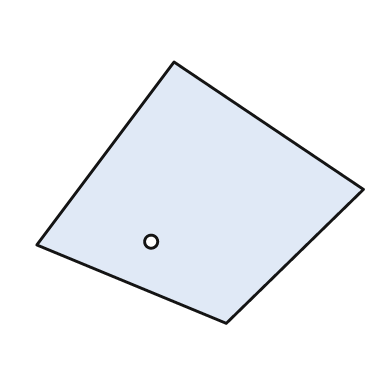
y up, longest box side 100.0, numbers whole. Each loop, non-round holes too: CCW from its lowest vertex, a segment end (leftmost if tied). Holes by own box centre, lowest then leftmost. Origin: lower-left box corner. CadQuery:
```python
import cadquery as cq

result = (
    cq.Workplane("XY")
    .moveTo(58.0, 0.0)
    .lineTo(100.0, 41.0)
    .lineTo(42.0, 80.0)
    .lineTo(0.0, 24.0)
    .close()
    .moveTo(35.0, 25.0)
    .circle(2.0)
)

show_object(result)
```